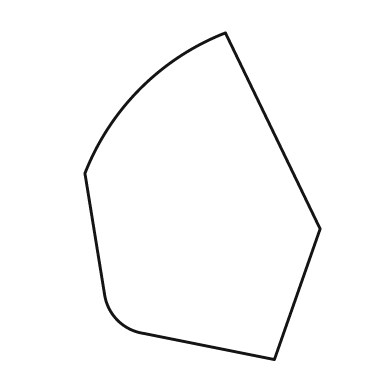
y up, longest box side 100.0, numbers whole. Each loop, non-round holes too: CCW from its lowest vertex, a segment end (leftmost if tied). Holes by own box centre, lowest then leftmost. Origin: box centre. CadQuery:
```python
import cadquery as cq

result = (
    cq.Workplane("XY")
    .moveTo(22.0, -50.0)
    .lineTo(36.0, -10.0)
    .lineTo(7.0, 50.0)
    .threePointArc((-19.0, 33.0), (-36.0, 7.0))
    .lineTo(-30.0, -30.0)
    .threePointArc((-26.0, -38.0), (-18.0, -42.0))
    .close()
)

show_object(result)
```